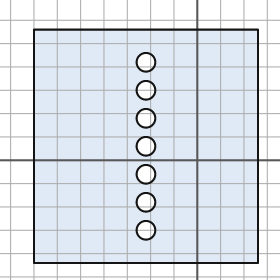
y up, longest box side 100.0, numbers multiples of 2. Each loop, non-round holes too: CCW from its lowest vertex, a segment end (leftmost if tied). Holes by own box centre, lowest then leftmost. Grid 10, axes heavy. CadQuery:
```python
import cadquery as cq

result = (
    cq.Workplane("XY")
    .moveTo(-70.0, -44.0)
    .lineTo(26.0, -44.0)
    .lineTo(26.0, 56.0)
    .lineTo(-70.0, 56.0)
    .close()
    .moveTo(-22.0, -30.0)
    .circle(4.0)
    .moveTo(-22.0, -18.0)
    .circle(4.0)
    .moveTo(-22.0, -6.0)
    .circle(4.0)
    .moveTo(-22.0, 6.0)
    .circle(4.0)
    .moveTo(-22.0, 18.0)
    .circle(4.0)
    .moveTo(-22.0, 30.0)
    .circle(4.0)
    .moveTo(-22.0, 42.0)
    .circle(4.0)
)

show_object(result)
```